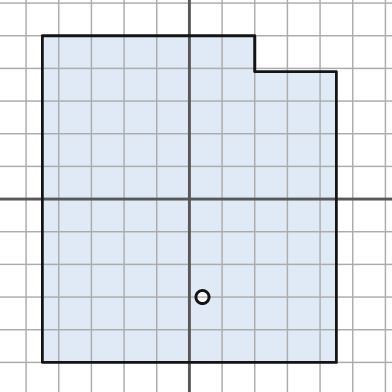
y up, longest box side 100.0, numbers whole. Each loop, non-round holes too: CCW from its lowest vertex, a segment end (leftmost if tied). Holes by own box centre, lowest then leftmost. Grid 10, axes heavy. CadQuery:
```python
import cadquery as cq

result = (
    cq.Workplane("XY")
    .moveTo(-45.0, -50.0)
    .lineTo(45.0, -50.0)
    .lineTo(45.0, 39.0)
    .lineTo(20.0, 39.0)
    .lineTo(20.0, 50.0)
    .lineTo(-45.0, 50.0)
    .close()
    .moveTo(4.0, -30.0)
    .circle(2.0)
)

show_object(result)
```